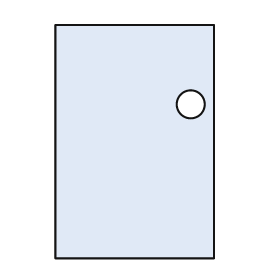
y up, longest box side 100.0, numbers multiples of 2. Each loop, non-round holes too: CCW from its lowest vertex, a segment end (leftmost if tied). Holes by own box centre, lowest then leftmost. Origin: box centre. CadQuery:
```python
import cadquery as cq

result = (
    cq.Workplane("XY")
    .moveTo(-34.0, -50.0)
    .lineTo(34.0, -50.0)
    .lineTo(34.0, 50.0)
    .lineTo(-34.0, 50.0)
    .close()
    .moveTo(24.0, 16.0)
    .circle(6.0)
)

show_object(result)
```